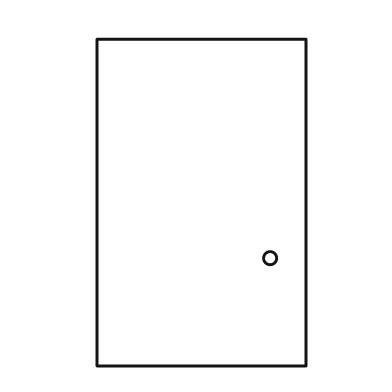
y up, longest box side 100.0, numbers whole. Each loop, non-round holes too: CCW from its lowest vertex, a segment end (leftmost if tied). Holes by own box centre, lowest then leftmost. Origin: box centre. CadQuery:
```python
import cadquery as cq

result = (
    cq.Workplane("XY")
    .moveTo(-32.0, -50.0)
    .lineTo(32.0, -50.0)
    .lineTo(32.0, 50.0)
    .lineTo(-32.0, 50.0)
    .close()
    .moveTo(21.0, -17.0)
    .circle(2.0)
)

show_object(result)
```